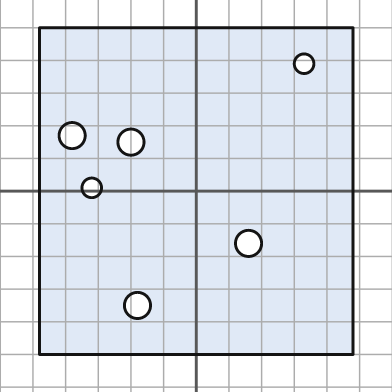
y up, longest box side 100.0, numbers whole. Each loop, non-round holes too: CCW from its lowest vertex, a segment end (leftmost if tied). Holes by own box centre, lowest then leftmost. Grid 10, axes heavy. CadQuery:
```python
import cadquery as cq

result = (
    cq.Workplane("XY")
    .moveTo(-48.0, -50.0)
    .lineTo(48.0, -50.0)
    .lineTo(48.0, 50.0)
    .lineTo(-48.0, 50.0)
    .close()
    .moveTo(-18.0, -35.0)
    .circle(4.0)
    .moveTo(16.0, -16.0)
    .circle(4.0)
    .moveTo(-32.0, 1.0)
    .circle(3.0)
    .moveTo(-20.0, 15.0)
    .circle(4.0)
    .moveTo(-38.0, 17.0)
    .circle(4.0)
    .moveTo(33.0, 39.0)
    .circle(3.0)
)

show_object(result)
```